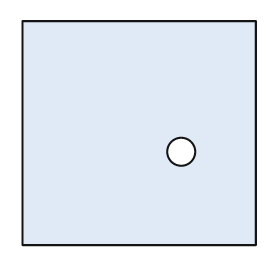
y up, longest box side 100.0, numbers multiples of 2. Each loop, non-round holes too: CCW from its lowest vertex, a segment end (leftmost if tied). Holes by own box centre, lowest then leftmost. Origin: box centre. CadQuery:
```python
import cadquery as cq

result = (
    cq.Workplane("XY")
    .moveTo(-50.0, -48.0)
    .lineTo(50.0, -48.0)
    .lineTo(50.0, 48.0)
    .lineTo(-50.0, 48.0)
    .close()
    .moveTo(18.0, -8.0)
    .circle(6.0)
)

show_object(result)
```